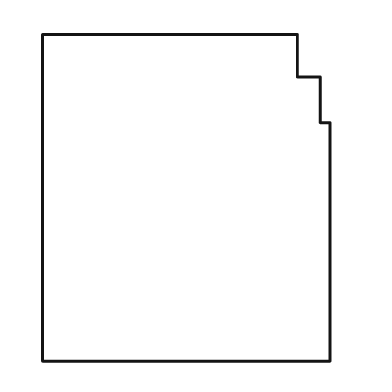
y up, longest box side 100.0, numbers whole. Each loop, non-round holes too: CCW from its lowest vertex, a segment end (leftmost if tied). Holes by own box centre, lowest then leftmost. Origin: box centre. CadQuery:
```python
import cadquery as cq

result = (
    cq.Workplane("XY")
    .moveTo(-44.0, -50.0)
    .lineTo(44.0, -50.0)
    .lineTo(44.0, 23.0)
    .lineTo(41.0, 23.0)
    .lineTo(41.0, 37.0)
    .lineTo(34.0, 37.0)
    .lineTo(34.0, 50.0)
    .lineTo(-44.0, 50.0)
    .close()
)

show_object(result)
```